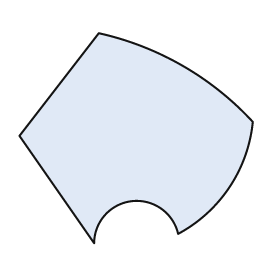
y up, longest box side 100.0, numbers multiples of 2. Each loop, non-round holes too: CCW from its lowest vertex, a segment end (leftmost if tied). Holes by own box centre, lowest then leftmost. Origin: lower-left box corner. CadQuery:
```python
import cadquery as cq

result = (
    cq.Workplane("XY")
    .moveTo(32.0, 0.0)
    .threePointArc((48.0, 18.0), (68.0, 4.0))
    .threePointArc((90.0, 24.0), (100.0, 52.0))
    .threePointArc((70.0, 76.0), (34.0, 90.0))
    .lineTo(0.0, 46.0)
    .close()
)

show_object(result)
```